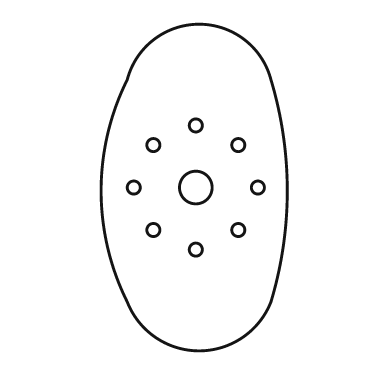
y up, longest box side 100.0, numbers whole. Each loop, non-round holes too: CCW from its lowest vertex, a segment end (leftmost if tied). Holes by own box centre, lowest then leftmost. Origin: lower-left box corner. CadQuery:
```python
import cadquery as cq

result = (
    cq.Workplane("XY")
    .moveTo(8.0, 15.0)
    .threePointArc((30.0, 0.0), (52.0, 15.0))
    .threePointArc((57.0, 49.0), (52.0, 83.0))
    .threePointArc((30.0, 100.0), (8.0, 83.0))
    .threePointArc((0.0, 49.0), (8.0, 15.0))
    .close()
    .moveTo(29.0, 31.0)
    .circle(2.0)
    .moveTo(16.0, 37.0)
    .circle(2.0)
    .moveTo(42.0, 37.0)
    .circle(2.0)
    .moveTo(10.0, 50.0)
    .circle(2.0)
    .moveTo(29.0, 50.0)
    .circle(5.0)
    .moveTo(48.0, 50.0)
    .circle(2.0)
    .moveTo(16.0, 63.0)
    .circle(2.0)
    .moveTo(42.0, 63.0)
    .circle(2.0)
    .moveTo(29.0, 69.0)
    .circle(2.0)
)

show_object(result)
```